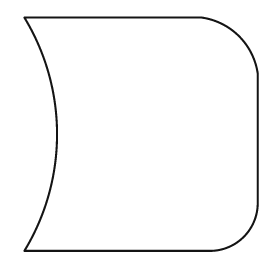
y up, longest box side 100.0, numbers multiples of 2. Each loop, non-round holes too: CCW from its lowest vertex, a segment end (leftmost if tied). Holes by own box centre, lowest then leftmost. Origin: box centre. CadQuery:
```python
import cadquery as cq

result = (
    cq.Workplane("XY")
    .moveTo(-50.0, -50.0)
    .lineTo(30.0, -50.0)
    .threePointArc((44.0, -44.0), (50.0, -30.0))
    .lineTo(50.0, 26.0)
    .threePointArc((42.0, 42.0), (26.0, 50.0))
    .lineTo(-50.0, 50.0)
    .threePointArc((-36.0, 0.0), (-50.0, -50.0))
    .close()
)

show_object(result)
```